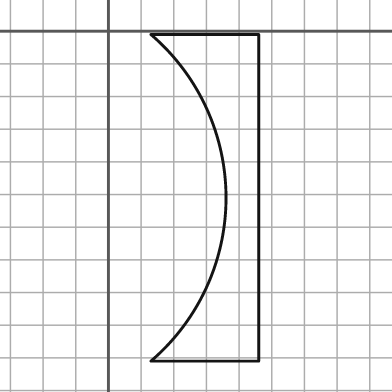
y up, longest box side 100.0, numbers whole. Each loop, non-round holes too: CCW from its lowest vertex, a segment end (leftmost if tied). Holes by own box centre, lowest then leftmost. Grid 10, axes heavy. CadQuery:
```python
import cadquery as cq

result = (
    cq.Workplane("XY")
    .moveTo(13.0, -101.0)
    .lineTo(46.0, -101.0)
    .lineTo(46.0, -1.0)
    .lineTo(13.0, -1.0)
    .threePointArc((36.0, -51.0), (13.0, -101.0))
    .close()
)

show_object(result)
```